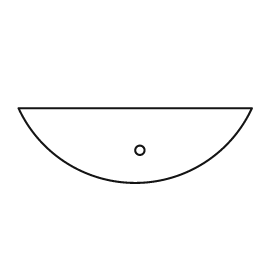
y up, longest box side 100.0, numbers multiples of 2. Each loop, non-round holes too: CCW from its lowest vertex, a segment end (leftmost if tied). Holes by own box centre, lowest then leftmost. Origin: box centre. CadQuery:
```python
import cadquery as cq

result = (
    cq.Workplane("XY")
    .moveTo(-50.0, 16.0)
    .threePointArc((0.0, -16.0), (50.0, 16.0))
    .close()
    .moveTo(2.0, -2.0)
    .circle(2.0)
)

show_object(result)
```